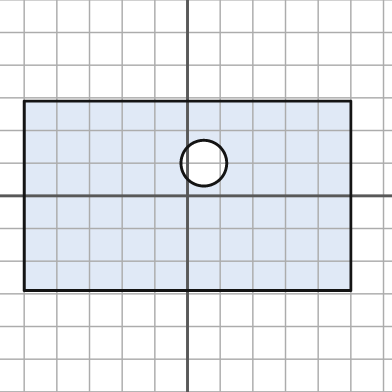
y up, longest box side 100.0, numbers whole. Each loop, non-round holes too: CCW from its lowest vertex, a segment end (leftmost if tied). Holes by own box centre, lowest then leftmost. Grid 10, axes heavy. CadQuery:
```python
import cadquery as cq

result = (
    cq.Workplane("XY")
    .moveTo(-50.0, -29.0)
    .lineTo(50.0, -29.0)
    .lineTo(50.0, 29.0)
    .lineTo(-50.0, 29.0)
    .close()
    .moveTo(5.0, 10.0)
    .circle(7.0)
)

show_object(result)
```